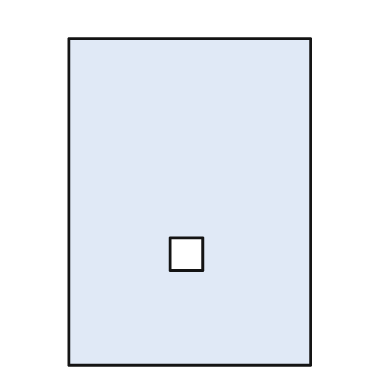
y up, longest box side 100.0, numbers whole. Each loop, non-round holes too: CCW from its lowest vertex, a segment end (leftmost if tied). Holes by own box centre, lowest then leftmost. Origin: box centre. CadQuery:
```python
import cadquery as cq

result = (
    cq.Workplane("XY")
    .moveTo(-37.0, -50.0)
    .lineTo(37.0, -50.0)
    .lineTo(37.0, 50.0)
    .lineTo(-37.0, 50.0)
    .close()
    .moveTo(-6.0, -21.0)
    .lineTo(4.0, -21.0)
    .lineTo(4.0, -11.0)
    .lineTo(-6.0, -11.0)
    .close()
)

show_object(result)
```